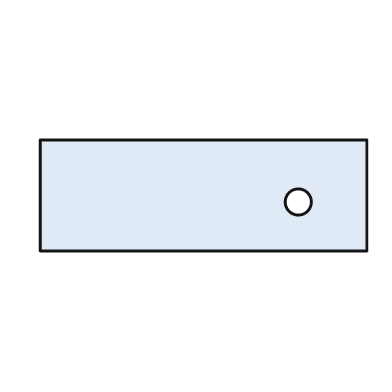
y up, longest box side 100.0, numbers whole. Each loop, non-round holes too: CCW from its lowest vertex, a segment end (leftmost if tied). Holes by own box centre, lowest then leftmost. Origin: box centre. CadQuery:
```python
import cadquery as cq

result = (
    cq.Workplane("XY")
    .moveTo(-50.0, -17.0)
    .lineTo(50.0, -17.0)
    .lineTo(50.0, 17.0)
    .lineTo(-50.0, 17.0)
    .close()
    .moveTo(29.0, -2.0)
    .circle(4.0)
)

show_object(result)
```